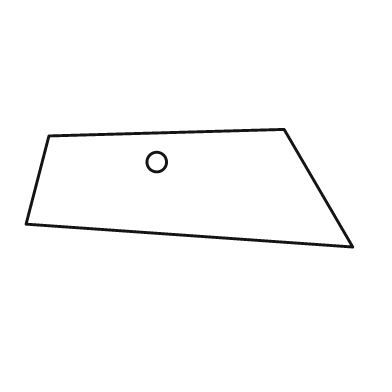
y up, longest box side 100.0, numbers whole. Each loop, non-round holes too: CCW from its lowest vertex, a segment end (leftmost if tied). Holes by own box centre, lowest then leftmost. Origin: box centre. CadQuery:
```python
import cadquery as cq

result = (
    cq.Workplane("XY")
    .moveTo(50.0, -18.0)
    .lineTo(29.0, 18.0)
    .lineTo(-43.0, 16.0)
    .lineTo(-50.0, -11.0)
    .close()
    .moveTo(-10.0, 8.0)
    .circle(3.0)
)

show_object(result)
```